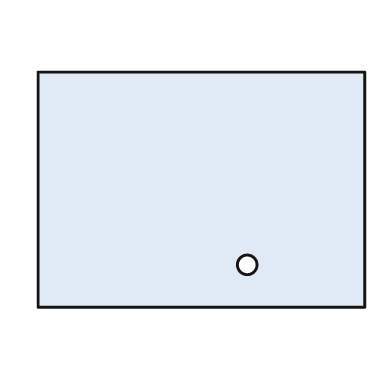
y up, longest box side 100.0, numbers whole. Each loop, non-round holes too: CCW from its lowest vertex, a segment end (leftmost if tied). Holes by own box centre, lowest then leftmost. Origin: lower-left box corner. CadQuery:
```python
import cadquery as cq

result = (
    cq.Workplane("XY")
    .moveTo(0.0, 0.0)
    .lineTo(100.0, 0.0)
    .lineTo(100.0, 72.0)
    .lineTo(0.0, 72.0)
    .close()
    .moveTo(64.0, 13.0)
    .circle(3.0)
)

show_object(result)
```